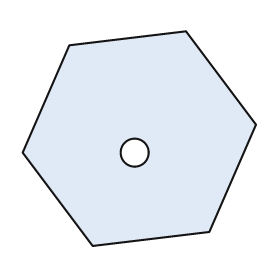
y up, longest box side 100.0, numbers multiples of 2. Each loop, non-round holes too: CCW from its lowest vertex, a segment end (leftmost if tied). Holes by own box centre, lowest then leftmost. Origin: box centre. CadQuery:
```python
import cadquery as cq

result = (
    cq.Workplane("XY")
    .moveTo(-20.0, -46.0)
    .lineTo(30.0, -40.0)
    .lineTo(50.0, 6.0)
    .lineTo(20.0, 46.0)
    .lineTo(-30.0, 40.0)
    .lineTo(-50.0, -6.0)
    .close()
    .moveTo(-2.0, -6.0)
    .circle(6.0)
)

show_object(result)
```